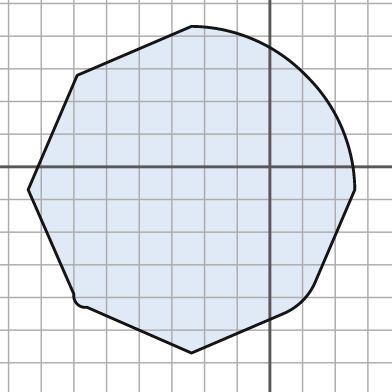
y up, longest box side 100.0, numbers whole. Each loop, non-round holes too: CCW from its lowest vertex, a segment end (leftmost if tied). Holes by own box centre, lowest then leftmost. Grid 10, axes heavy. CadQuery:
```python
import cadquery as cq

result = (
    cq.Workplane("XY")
    .moveTo(-24.0, -57.0)
    .lineTo(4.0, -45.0)
    .threePointArc((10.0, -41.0), (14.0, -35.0))
    .lineTo(26.0, -7.0)
    .threePointArc((22.0, 12.0), (11.0, 28.0))
    .threePointArc((-5.0, 39.0), (-24.0, 43.0))
    .lineTo(-59.0, 28.0)
    .lineTo(-74.0, -7.0)
    .lineTo(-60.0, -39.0)
    .threePointArc((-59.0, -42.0), (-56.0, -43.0))
    .close()
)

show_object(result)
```